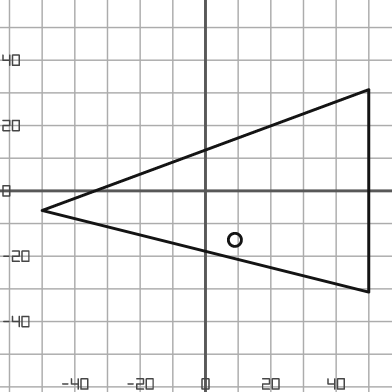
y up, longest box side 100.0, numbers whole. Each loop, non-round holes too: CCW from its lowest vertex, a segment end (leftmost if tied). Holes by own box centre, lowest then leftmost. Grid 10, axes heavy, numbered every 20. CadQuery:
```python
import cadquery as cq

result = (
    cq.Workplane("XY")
    .moveTo(50.0, -31.0)
    .lineTo(50.0, 31.0)
    .lineTo(-50.0, -6.0)
    .close()
    .moveTo(9.0, -15.0)
    .circle(2.0)
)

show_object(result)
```